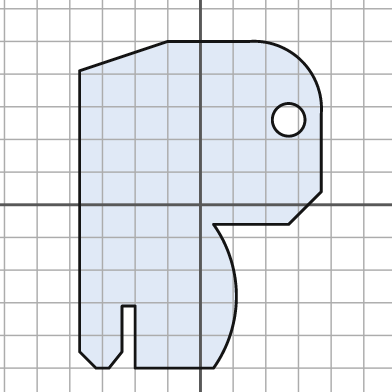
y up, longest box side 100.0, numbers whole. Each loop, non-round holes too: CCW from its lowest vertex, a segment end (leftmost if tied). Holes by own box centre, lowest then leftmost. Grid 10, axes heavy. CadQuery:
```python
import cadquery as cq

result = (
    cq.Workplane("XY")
    .moveTo(-32.0, -50.0)
    .lineTo(-28.0, -50.0)
    .lineTo(-24.0, -45.0)
    .lineTo(-24.0, -31.0)
    .lineTo(-20.0, -31.0)
    .lineTo(-20.0, -50.0)
    .lineTo(4.0, -50.0)
    .threePointArc((11.0, -28.0), (4.0, -6.0))
    .lineTo(27.0, -6.0)
    .lineTo(37.0, 4.0)
    .lineTo(37.0, 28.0)
    .threePointArc((31.0, 44.0), (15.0, 50.0))
    .lineTo(-10.0, 50.0)
    .lineTo(-37.0, 41.0)
    .lineTo(-37.0, -45.0)
    .close()
    .moveTo(27.0, 26.0)
    .circle(5.0)
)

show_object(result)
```